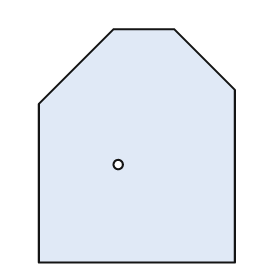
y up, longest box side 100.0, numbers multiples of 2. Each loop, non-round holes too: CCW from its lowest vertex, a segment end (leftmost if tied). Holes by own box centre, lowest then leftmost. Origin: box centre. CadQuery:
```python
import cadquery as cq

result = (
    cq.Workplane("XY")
    .moveTo(-42.0, -50.0)
    .lineTo(42.0, -50.0)
    .lineTo(42.0, 24.0)
    .lineTo(16.0, 50.0)
    .lineTo(-10.0, 50.0)
    .lineTo(-42.0, 18.0)
    .close()
    .moveTo(-8.0, -8.0)
    .circle(2.0)
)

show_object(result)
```